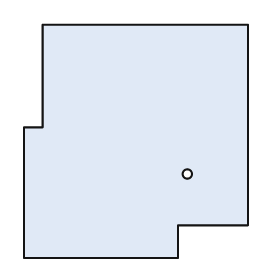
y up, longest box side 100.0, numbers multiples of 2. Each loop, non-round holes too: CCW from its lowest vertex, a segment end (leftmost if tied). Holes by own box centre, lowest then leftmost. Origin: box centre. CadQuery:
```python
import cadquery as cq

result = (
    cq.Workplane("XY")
    .moveTo(-48.0, -50.0)
    .lineTo(18.0, -50.0)
    .lineTo(18.0, -36.0)
    .lineTo(48.0, -36.0)
    .lineTo(48.0, 50.0)
    .lineTo(-40.0, 50.0)
    .lineTo(-40.0, 6.0)
    .lineTo(-48.0, 6.0)
    .close()
    .moveTo(22.0, -14.0)
    .circle(2.0)
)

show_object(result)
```